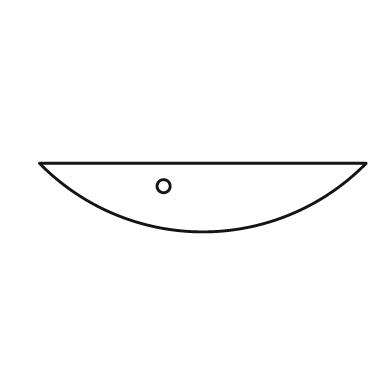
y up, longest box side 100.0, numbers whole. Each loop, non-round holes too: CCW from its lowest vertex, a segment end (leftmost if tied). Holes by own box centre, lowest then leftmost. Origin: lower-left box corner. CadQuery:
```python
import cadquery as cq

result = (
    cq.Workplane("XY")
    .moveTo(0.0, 21.0)
    .threePointArc((50.0, 0.0), (100.0, 21.0))
    .close()
    .moveTo(38.0, 14.0)
    .circle(2.0)
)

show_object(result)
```